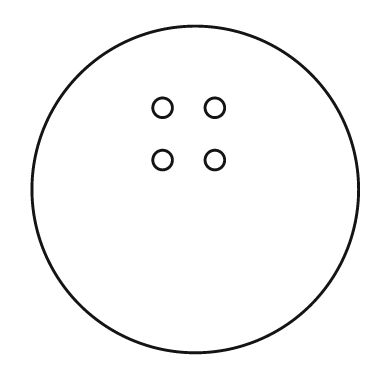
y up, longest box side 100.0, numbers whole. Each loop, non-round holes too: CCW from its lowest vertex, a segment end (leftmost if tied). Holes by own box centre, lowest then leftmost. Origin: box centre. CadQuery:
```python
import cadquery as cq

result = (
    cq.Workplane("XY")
    .moveTo(0.0, 0.0)
    .circle(50.0)
    .moveTo(-10.0, 9.0)
    .circle(3.0)
    .moveTo(6.0, 9.0)
    .circle(3.0)
    .moveTo(-10.0, 25.0)
    .circle(3.0)
    .moveTo(6.0, 25.0)
    .circle(3.0)
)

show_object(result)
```